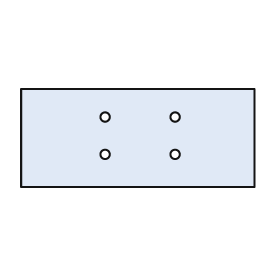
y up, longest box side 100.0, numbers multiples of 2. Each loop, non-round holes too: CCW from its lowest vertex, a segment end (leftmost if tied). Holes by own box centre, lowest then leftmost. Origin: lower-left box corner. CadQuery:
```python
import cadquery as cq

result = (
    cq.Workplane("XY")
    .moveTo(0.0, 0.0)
    .lineTo(100.0, 0.0)
    .lineTo(100.0, 42.0)
    .lineTo(0.0, 42.0)
    .close()
    .moveTo(36.0, 14.0)
    .circle(2.0)
    .moveTo(66.0, 14.0)
    .circle(2.0)
    .moveTo(36.0, 30.0)
    .circle(2.0)
    .moveTo(66.0, 30.0)
    .circle(2.0)
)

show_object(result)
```